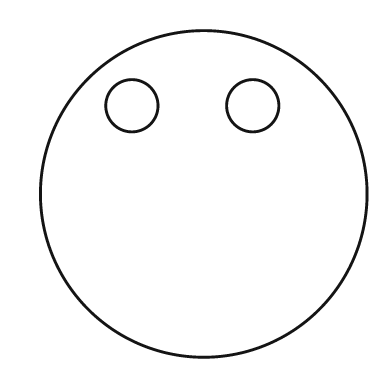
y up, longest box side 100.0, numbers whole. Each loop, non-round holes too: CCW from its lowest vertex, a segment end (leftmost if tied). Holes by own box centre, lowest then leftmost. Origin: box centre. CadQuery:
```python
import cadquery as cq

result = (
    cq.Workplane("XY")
    .moveTo(0.0, 0.0)
    .circle(50.0)
    .moveTo(-22.0, 27.0)
    .circle(8.0)
    .moveTo(15.0, 27.0)
    .circle(8.0)
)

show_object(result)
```